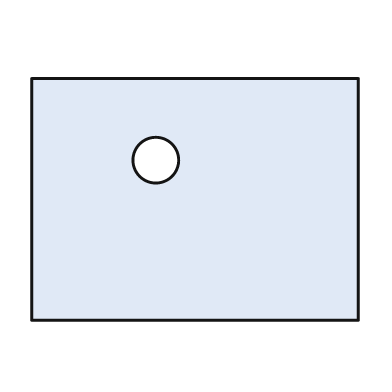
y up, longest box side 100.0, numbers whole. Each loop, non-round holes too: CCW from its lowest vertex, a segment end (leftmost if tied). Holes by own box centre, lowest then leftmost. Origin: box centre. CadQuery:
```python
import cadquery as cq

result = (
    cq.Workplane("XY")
    .moveTo(-50.0, -37.0)
    .lineTo(50.0, -37.0)
    .lineTo(50.0, 37.0)
    .lineTo(-50.0, 37.0)
    .close()
    .moveTo(-12.0, 12.0)
    .circle(7.0)
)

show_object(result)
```